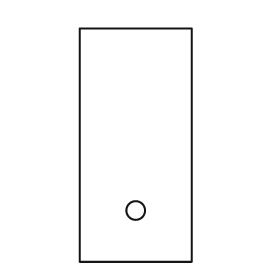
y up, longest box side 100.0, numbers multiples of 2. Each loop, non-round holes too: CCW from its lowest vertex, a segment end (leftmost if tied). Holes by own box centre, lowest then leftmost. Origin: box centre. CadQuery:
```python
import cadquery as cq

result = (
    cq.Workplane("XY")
    .moveTo(-24.0, -50.0)
    .lineTo(24.0, -50.0)
    .lineTo(24.0, 50.0)
    .lineTo(-24.0, 50.0)
    .close()
    .moveTo(0.0, -28.0)
    .circle(4.0)
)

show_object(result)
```